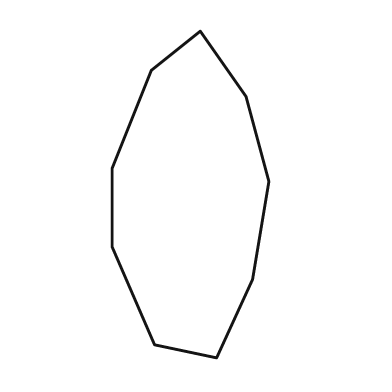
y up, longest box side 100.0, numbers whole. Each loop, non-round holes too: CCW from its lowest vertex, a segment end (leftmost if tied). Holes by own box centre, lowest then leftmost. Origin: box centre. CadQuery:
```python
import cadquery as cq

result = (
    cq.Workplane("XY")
    .moveTo(8.0, -50.0)
    .lineTo(19.0, -26.0)
    .lineTo(24.0, 4.0)
    .lineTo(17.0, 30.0)
    .lineTo(3.0, 50.0)
    .lineTo(-12.0, 38.0)
    .lineTo(-24.0, 8.0)
    .lineTo(-24.0, -16.0)
    .lineTo(-11.0, -46.0)
    .close()
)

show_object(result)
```